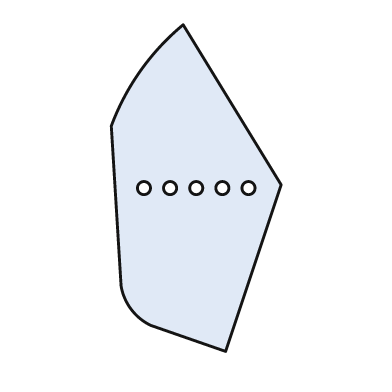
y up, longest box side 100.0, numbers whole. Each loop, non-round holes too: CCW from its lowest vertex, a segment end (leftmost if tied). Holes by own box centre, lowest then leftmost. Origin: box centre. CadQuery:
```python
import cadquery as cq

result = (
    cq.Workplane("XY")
    .moveTo(9.0, -50.0)
    .lineTo(26.0, 1.0)
    .lineTo(-4.0, 50.0)
    .threePointArc((-17.0, 36.0), (-26.0, 19.0))
    .lineTo(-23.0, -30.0)
    .threePointArc((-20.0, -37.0), (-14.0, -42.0))
    .close()
    .moveTo(-16.0, 0.0)
    .circle(2.0)
    .moveTo(-8.0, 0.0)
    .circle(2.0)
    .moveTo(0.0, 0.0)
    .circle(2.0)
    .moveTo(8.0, 0.0)
    .circle(2.0)
    .moveTo(16.0, 0.0)
    .circle(2.0)
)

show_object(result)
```